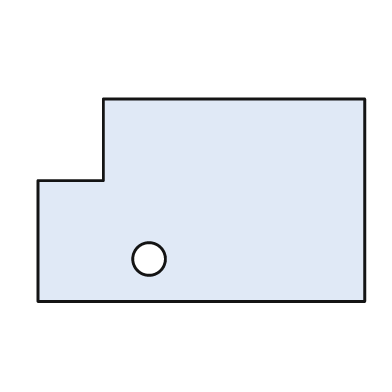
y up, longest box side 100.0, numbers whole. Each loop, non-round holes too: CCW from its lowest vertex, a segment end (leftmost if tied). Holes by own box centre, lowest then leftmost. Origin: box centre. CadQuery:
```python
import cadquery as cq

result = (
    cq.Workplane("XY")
    .moveTo(-50.0, -31.0)
    .lineTo(50.0, -31.0)
    .lineTo(50.0, 31.0)
    .lineTo(-30.0, 31.0)
    .lineTo(-30.0, 6.0)
    .lineTo(-50.0, 6.0)
    .close()
    .moveTo(-16.0, -18.0)
    .circle(5.0)
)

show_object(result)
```